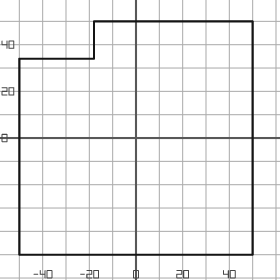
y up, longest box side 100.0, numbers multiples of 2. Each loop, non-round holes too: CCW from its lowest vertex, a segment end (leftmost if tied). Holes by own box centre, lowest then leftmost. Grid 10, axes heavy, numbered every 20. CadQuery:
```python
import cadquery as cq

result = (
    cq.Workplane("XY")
    .moveTo(-50.0, -50.0)
    .lineTo(50.0, -50.0)
    .lineTo(50.0, 50.0)
    .lineTo(-18.0, 50.0)
    .lineTo(-18.0, 34.0)
    .lineTo(-50.0, 34.0)
    .close()
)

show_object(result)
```